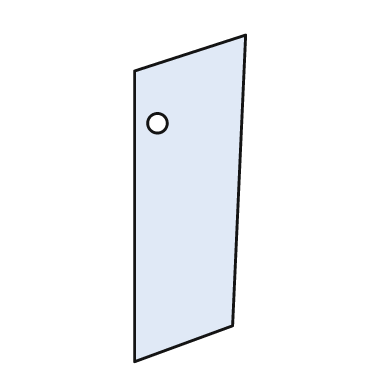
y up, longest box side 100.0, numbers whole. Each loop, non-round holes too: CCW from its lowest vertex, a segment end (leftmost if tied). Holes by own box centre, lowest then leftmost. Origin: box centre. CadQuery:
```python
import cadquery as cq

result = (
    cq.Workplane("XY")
    .moveTo(-17.0, -50.0)
    .lineTo(13.0, -39.0)
    .lineTo(17.0, 50.0)
    .lineTo(-17.0, 39.0)
    .close()
    .moveTo(-10.0, 23.0)
    .circle(3.0)
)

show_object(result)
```